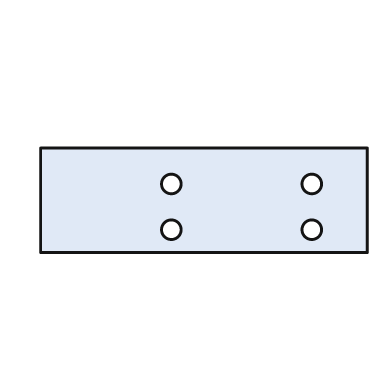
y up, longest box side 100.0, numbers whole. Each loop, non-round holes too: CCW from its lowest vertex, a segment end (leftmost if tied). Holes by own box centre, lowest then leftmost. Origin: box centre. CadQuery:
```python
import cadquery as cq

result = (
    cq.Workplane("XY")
    .moveTo(-50.0, -16.0)
    .lineTo(50.0, -16.0)
    .lineTo(50.0, 16.0)
    .lineTo(-50.0, 16.0)
    .close()
    .moveTo(-10.0, -9.0)
    .circle(3.0)
    .moveTo(33.0, -9.0)
    .circle(3.0)
    .moveTo(-10.0, 5.0)
    .circle(3.0)
    .moveTo(33.0, 5.0)
    .circle(3.0)
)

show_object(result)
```